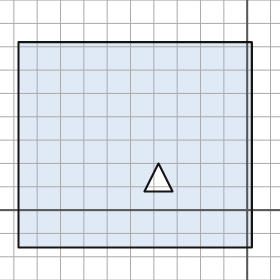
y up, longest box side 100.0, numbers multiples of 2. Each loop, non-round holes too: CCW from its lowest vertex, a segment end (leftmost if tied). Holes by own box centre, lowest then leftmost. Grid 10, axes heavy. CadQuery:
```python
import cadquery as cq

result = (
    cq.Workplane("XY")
    .moveTo(-98.0, -16.0)
    .lineTo(2.0, -16.0)
    .lineTo(2.0, 72.0)
    .lineTo(-98.0, 72.0)
    .close()
    .moveTo(-44.0, 8.0)
    .lineTo(-32.0, 8.0)
    .lineTo(-38.0, 20.0)
    .close()
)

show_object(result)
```